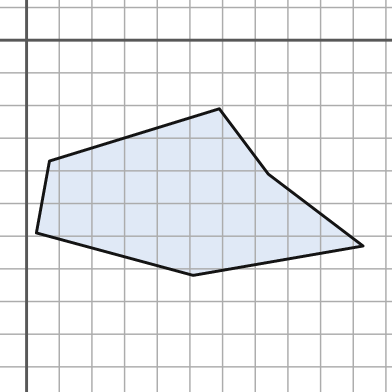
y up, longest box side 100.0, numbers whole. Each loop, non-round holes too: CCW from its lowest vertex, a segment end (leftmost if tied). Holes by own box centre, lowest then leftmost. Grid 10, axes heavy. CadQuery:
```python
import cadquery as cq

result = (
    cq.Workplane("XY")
    .moveTo(51.0, -72.0)
    .lineTo(103.0, -63.0)
    .lineTo(74.0, -41.0)
    .lineTo(59.0, -21.0)
    .lineTo(7.0, -37.0)
    .lineTo(3.0, -59.0)
    .close()
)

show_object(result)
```